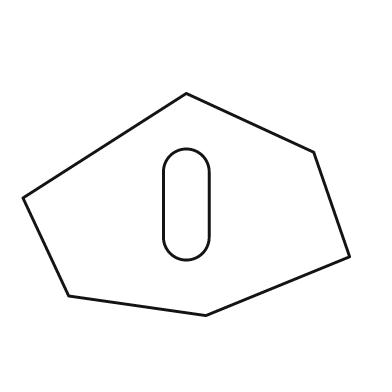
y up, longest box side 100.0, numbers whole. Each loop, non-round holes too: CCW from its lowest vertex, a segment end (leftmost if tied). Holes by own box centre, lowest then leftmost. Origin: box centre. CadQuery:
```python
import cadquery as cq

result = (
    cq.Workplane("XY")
    .moveTo(6.0, -34.0)
    .lineTo(50.0, -16.0)
    .lineTo(39.0, 16.0)
    .lineTo(0.0, 34.0)
    .lineTo(-50.0, 2.0)
    .lineTo(-36.0, -28.0)
    .close()
    .moveTo(-7.0, -10.0)
    .threePointArc((0.0, -17.0), (7.0, -10.0))
    .lineTo(7.0, 10.0)
    .threePointArc((0.0, 17.0), (-7.0, 10.0))
    .close()
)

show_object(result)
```